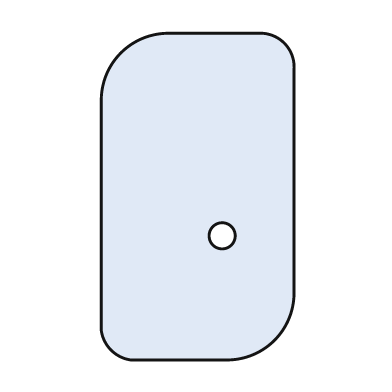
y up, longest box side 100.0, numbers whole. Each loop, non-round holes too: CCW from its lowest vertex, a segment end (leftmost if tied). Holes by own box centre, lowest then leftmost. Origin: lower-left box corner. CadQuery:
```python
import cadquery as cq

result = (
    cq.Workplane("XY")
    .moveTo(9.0, 0.0)
    .lineTo(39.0, 0.0)
    .threePointArc((53.0, 6.0), (59.0, 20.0))
    .lineTo(59.0, 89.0)
    .threePointArc((56.0, 97.0), (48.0, 100.0))
    .lineTo(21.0, 100.0)
    .threePointArc((6.0, 94.0), (0.0, 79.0))
    .lineTo(0.0, 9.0)
    .threePointArc((3.0, 3.0), (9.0, 0.0))
    .close()
    .moveTo(37.0, 38.0)
    .circle(4.0)
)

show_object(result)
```